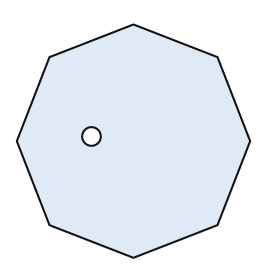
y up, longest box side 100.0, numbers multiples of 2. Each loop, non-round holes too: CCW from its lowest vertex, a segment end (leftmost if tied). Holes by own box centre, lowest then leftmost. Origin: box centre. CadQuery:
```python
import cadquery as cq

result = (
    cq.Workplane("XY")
    .moveTo(0.0, -50.0)
    .lineTo(36.0, -36.0)
    .lineTo(50.0, 0.0)
    .lineTo(36.0, 36.0)
    .lineTo(0.0, 50.0)
    .lineTo(-36.0, 36.0)
    .lineTo(-50.0, 0.0)
    .lineTo(-36.0, -36.0)
    .close()
    .moveTo(-18.0, 2.0)
    .circle(4.0)
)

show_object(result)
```